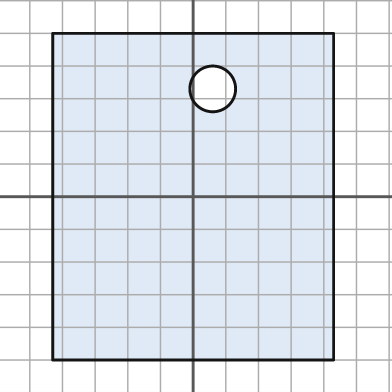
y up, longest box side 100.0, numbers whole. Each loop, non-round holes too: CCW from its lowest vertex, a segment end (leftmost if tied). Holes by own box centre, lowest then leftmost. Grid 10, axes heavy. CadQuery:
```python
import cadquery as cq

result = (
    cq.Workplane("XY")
    .moveTo(-43.0, -50.0)
    .lineTo(43.0, -50.0)
    .lineTo(43.0, 50.0)
    .lineTo(-43.0, 50.0)
    .close()
    .moveTo(6.0, 33.0)
    .circle(7.0)
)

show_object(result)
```